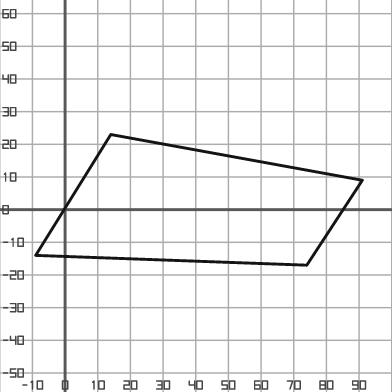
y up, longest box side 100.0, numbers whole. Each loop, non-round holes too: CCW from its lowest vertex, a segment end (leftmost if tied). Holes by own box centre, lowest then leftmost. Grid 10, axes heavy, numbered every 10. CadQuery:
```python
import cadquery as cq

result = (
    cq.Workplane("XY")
    .moveTo(74.0, -17.0)
    .lineTo(91.0, 9.0)
    .lineTo(14.0, 23.0)
    .lineTo(-9.0, -14.0)
    .close()
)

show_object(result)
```